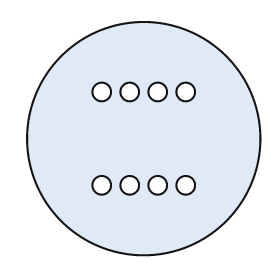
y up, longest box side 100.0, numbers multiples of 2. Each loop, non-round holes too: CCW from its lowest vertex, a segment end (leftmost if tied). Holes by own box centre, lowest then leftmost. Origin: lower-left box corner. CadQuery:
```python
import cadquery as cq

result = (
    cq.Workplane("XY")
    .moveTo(50.0, 50.0)
    .circle(50.0)
    .moveTo(32.0, 30.0)
    .circle(4.0)
    .moveTo(44.0, 30.0)
    .circle(4.0)
    .moveTo(56.0, 30.0)
    .circle(4.0)
    .moveTo(68.0, 30.0)
    .circle(4.0)
    .moveTo(32.0, 70.0)
    .circle(4.0)
    .moveTo(44.0, 70.0)
    .circle(4.0)
    .moveTo(56.0, 70.0)
    .circle(4.0)
    .moveTo(68.0, 70.0)
    .circle(4.0)
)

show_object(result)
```